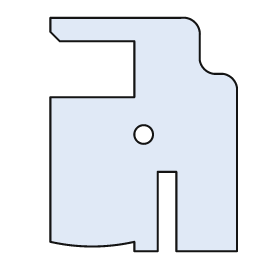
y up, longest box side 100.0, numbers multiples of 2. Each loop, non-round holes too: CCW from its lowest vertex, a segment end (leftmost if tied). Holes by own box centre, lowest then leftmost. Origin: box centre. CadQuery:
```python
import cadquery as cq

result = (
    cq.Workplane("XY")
    .moveTo(-4.0, -50.0)
    .lineTo(6.0, -50.0)
    .lineTo(6.0, -16.0)
    .lineTo(14.0, -16.0)
    .lineTo(14.0, -50.0)
    .lineTo(40.0, -50.0)
    .lineTo(40.0, 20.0)
    .threePointArc((38.0, 24.0), (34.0, 26.0))
    .lineTo(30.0, 26.0)
    .threePointArc((26.0, 28.0), (24.0, 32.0))
    .lineTo(24.0, 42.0)
    .threePointArc((22.0, 48.0), (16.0, 50.0))
    .lineTo(-40.0, 50.0)
    .lineTo(-40.0, 44.0)
    .lineTo(-36.0, 40.0)
    .lineTo(-4.0, 40.0)
    .lineTo(-4.0, 16.0)
    .lineTo(-40.0, 16.0)
    .lineTo(-40.0, -46.0)
    .threePointArc((-22.0, -48.0), (-4.0, -46.0))
    .close()
    .moveTo(0.0, 0.0)
    .circle(4.0)
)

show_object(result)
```